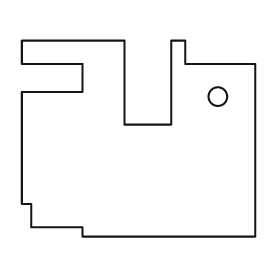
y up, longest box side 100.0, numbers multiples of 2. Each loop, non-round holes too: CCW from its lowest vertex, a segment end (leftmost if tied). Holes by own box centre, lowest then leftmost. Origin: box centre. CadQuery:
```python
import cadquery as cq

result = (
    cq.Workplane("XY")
    .moveTo(-24.0, -42.0)
    .lineTo(50.0, -42.0)
    .lineTo(50.0, 32.0)
    .lineTo(20.0, 32.0)
    .lineTo(20.0, 42.0)
    .lineTo(14.0, 42.0)
    .lineTo(14.0, 6.0)
    .lineTo(-6.0, 6.0)
    .lineTo(-6.0, 42.0)
    .lineTo(-50.0, 42.0)
    .lineTo(-50.0, 32.0)
    .lineTo(-24.0, 32.0)
    .lineTo(-24.0, 20.0)
    .lineTo(-50.0, 20.0)
    .lineTo(-50.0, -28.0)
    .lineTo(-46.0, -28.0)
    .lineTo(-46.0, -38.0)
    .lineTo(-24.0, -38.0)
    .close()
    .moveTo(34.0, 18.0)
    .circle(4.0)
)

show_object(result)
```